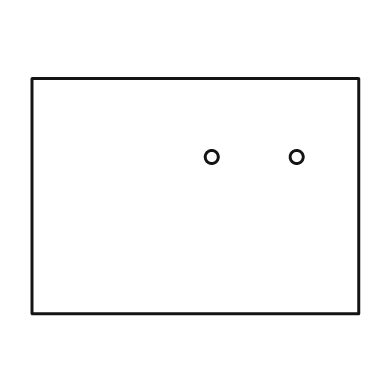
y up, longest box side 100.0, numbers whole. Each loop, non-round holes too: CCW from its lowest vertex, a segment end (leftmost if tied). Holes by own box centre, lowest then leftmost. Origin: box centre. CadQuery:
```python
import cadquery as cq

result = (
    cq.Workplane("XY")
    .moveTo(-50.0, -36.0)
    .lineTo(50.0, -36.0)
    .lineTo(50.0, 36.0)
    .lineTo(-50.0, 36.0)
    .close()
    .moveTo(5.0, 12.0)
    .circle(2.0)
    .moveTo(31.0, 12.0)
    .circle(2.0)
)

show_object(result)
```